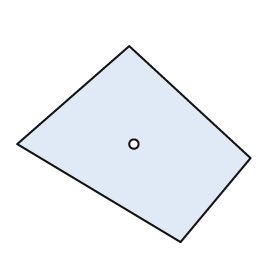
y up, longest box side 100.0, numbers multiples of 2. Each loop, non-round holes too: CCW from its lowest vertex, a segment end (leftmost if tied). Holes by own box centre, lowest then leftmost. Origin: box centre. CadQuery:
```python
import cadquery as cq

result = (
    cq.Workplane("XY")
    .moveTo(20.0, -42.0)
    .lineTo(50.0, -6.0)
    .lineTo(-2.0, 42.0)
    .lineTo(-50.0, 0.0)
    .close()
    .moveTo(0.0, 0.0)
    .circle(2.0)
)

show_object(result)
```